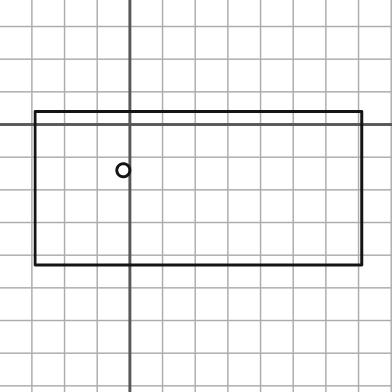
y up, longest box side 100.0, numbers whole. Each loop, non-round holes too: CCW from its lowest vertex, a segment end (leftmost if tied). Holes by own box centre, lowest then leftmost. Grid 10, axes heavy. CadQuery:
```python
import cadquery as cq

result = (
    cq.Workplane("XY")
    .moveTo(-29.0, -43.0)
    .lineTo(71.0, -43.0)
    .lineTo(71.0, 4.0)
    .lineTo(-29.0, 4.0)
    .close()
    .moveTo(-2.0, -14.0)
    .circle(2.0)
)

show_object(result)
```